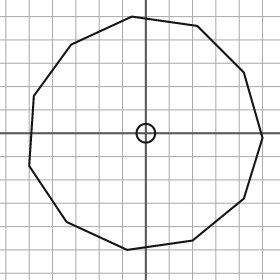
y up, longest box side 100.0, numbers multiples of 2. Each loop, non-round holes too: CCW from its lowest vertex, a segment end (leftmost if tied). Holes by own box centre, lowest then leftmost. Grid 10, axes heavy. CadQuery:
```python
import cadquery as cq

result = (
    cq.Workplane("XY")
    .moveTo(-8.0, -50.0)
    .lineTo(20.0, -46.0)
    .lineTo(42.0, -28.0)
    .lineTo(50.0, -2.0)
    .lineTo(42.0, 26.0)
    .lineTo(22.0, 46.0)
    .lineTo(-6.0, 50.0)
    .lineTo(-32.0, 38.0)
    .lineTo(-48.0, 16.0)
    .lineTo(-50.0, -14.0)
    .lineTo(-34.0, -38.0)
    .close()
    .moveTo(0.0, 0.0)
    .circle(4.0)
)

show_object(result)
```